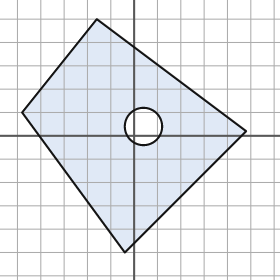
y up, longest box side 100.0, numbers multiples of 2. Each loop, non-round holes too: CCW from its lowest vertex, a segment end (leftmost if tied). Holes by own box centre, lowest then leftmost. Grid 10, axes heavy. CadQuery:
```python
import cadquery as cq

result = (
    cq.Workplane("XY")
    .moveTo(-4.0, -50.0)
    .lineTo(48.0, 2.0)
    .lineTo(-16.0, 50.0)
    .lineTo(-48.0, 10.0)
    .close()
    .moveTo(4.0, 4.0)
    .circle(8.0)
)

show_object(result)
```